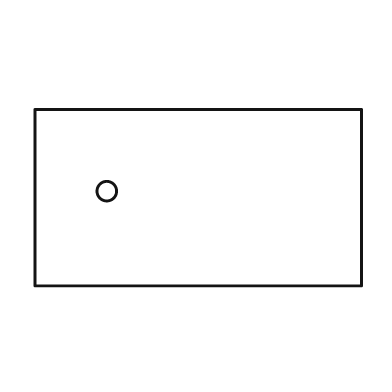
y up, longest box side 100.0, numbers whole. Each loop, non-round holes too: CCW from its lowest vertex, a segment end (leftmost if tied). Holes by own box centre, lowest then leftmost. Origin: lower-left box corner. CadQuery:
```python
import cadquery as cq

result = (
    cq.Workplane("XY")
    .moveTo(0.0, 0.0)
    .lineTo(100.0, 0.0)
    .lineTo(100.0, 54.0)
    .lineTo(0.0, 54.0)
    .close()
    .moveTo(22.0, 29.0)
    .circle(3.0)
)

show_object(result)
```